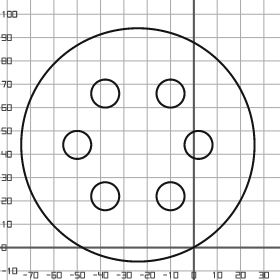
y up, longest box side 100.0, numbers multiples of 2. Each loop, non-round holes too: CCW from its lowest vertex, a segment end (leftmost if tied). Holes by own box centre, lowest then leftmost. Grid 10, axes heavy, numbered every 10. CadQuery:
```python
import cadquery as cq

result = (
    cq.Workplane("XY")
    .moveTo(-24.0, 44.0)
    .circle(50.0)
    .moveTo(-38.0, 22.0)
    .circle(6.0)
    .moveTo(-10.0, 22.0)
    .circle(6.0)
    .moveTo(-50.0, 44.0)
    .circle(6.0)
    .moveTo(2.0, 44.0)
    .circle(6.0)
    .moveTo(-38.0, 66.0)
    .circle(6.0)
    .moveTo(-10.0, 66.0)
    .circle(6.0)
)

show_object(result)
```